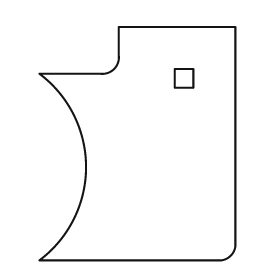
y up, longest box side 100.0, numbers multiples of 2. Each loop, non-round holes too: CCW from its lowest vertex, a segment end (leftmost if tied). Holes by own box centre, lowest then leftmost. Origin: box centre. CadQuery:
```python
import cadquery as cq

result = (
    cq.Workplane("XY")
    .moveTo(-42.0, -50.0)
    .lineTo(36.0, -50.0)
    .threePointArc((40.0, -48.0), (42.0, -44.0))
    .lineTo(42.0, 50.0)
    .lineTo(-8.0, 50.0)
    .lineTo(-8.0, 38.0)
    .threePointArc((-10.0, 32.0), (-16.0, 30.0))
    .lineTo(-42.0, 30.0)
    .threePointArc((-22.0, -10.0), (-42.0, -50.0))
    .close()
    .moveTo(16.0, 24.0)
    .lineTo(24.0, 24.0)
    .lineTo(24.0, 32.0)
    .lineTo(16.0, 32.0)
    .close()
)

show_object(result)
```